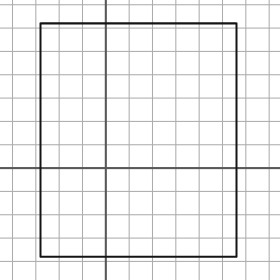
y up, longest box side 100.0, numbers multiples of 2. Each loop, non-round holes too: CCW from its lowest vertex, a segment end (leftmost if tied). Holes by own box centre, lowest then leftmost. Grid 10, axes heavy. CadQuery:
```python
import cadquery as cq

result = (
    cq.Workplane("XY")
    .moveTo(-28.0, -38.0)
    .lineTo(56.0, -38.0)
    .lineTo(56.0, 62.0)
    .lineTo(-28.0, 62.0)
    .close()
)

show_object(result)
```